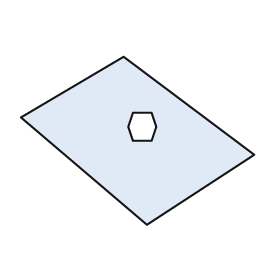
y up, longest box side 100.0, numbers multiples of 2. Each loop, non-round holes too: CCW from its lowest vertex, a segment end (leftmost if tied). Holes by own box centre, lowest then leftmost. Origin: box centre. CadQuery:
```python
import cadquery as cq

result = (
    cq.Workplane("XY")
    .moveTo(4.0, -36.0)
    .lineTo(50.0, -6.0)
    .lineTo(-6.0, 36.0)
    .lineTo(-50.0, 10.0)
    .close()
    .moveTo(-2.0, 0.0)
    .lineTo(6.0, 0.0)
    .lineTo(8.0, 6.0)
    .lineTo(6.0, 12.0)
    .lineTo(-2.0, 12.0)
    .lineTo(-4.0, 6.0)
    .close()
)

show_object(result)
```